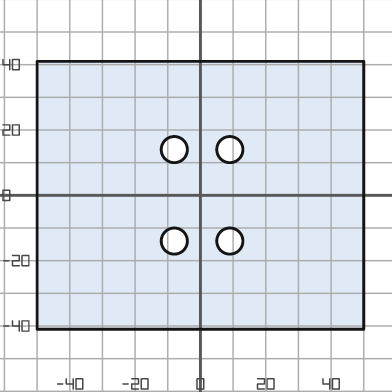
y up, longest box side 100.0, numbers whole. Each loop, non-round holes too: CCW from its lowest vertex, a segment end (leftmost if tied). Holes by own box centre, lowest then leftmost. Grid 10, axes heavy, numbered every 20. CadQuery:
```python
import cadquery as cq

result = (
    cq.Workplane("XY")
    .moveTo(-50.0, -41.0)
    .lineTo(50.0, -41.0)
    .lineTo(50.0, 41.0)
    .lineTo(-50.0, 41.0)
    .close()
    .moveTo(-8.0, -14.0)
    .circle(4.0)
    .moveTo(9.0, -14.0)
    .circle(4.0)
    .moveTo(-8.0, 14.0)
    .circle(4.0)
    .moveTo(9.0, 14.0)
    .circle(4.0)
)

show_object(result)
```